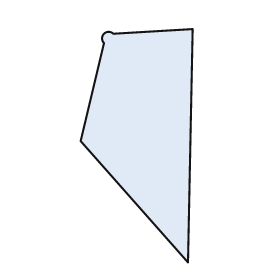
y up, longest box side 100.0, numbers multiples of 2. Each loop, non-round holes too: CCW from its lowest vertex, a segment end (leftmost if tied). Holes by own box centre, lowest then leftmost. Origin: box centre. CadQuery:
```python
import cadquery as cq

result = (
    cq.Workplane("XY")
    .moveTo(22.0, -50.0)
    .lineTo(24.0, 50.0)
    .lineTo(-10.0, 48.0)
    .threePointArc((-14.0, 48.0), (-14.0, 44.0))
    .lineTo(-24.0, 2.0)
    .close()
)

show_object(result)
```